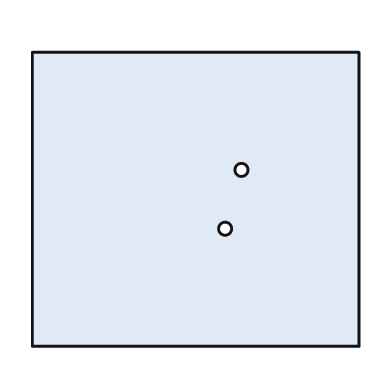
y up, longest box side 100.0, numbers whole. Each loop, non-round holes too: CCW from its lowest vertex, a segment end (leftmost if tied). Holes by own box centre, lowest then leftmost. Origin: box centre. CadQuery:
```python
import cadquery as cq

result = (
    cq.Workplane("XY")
    .moveTo(-50.0, -45.0)
    .lineTo(50.0, -45.0)
    .lineTo(50.0, 45.0)
    .lineTo(-50.0, 45.0)
    .close()
    .moveTo(9.0, -9.0)
    .circle(2.0)
    .moveTo(14.0, 9.0)
    .circle(2.0)
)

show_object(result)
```